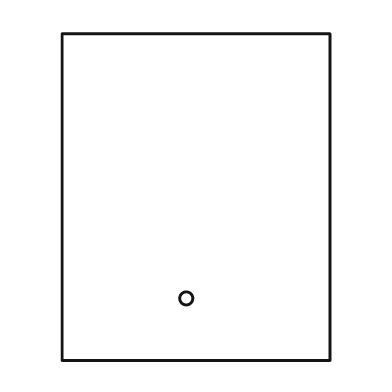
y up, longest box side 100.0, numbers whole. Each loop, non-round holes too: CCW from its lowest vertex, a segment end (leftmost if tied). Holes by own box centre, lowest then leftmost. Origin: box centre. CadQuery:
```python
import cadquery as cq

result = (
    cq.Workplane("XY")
    .moveTo(-41.0, -50.0)
    .lineTo(41.0, -50.0)
    .lineTo(41.0, 50.0)
    .lineTo(-41.0, 50.0)
    .close()
    .moveTo(-3.0, -31.0)
    .circle(2.0)
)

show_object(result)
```